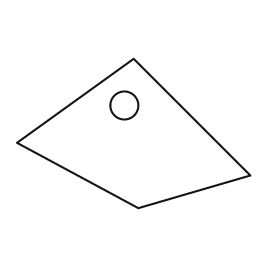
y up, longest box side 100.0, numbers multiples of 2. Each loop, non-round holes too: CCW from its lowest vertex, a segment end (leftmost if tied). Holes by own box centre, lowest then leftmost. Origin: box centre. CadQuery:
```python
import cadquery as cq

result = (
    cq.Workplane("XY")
    .moveTo(2.0, -32.0)
    .lineTo(50.0, -18.0)
    .lineTo(0.0, 32.0)
    .lineTo(-50.0, -4.0)
    .close()
    .moveTo(-4.0, 12.0)
    .circle(6.0)
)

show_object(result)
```